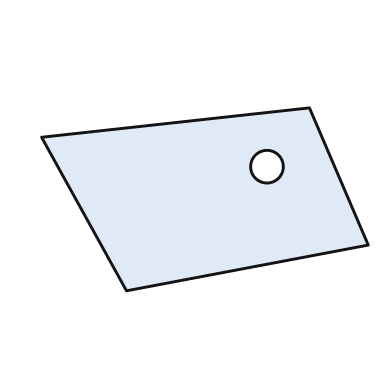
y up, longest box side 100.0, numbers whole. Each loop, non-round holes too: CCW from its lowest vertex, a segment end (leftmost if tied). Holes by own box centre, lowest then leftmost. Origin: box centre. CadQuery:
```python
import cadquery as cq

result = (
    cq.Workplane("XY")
    .moveTo(-24.0, -28.0)
    .lineTo(50.0, -14.0)
    .lineTo(32.0, 28.0)
    .lineTo(-50.0, 19.0)
    .close()
    .moveTo(19.0, 10.0)
    .circle(5.0)
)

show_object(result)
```